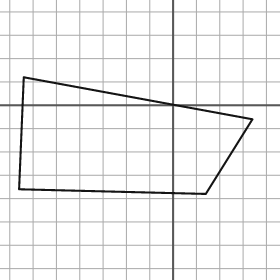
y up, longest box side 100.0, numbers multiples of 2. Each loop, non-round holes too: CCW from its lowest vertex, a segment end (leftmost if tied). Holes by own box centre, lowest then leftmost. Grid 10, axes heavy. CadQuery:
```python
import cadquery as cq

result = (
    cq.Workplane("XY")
    .moveTo(14.0, -38.0)
    .lineTo(34.0, -6.0)
    .lineTo(-64.0, 12.0)
    .lineTo(-66.0, -36.0)
    .close()
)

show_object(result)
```